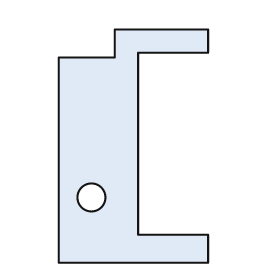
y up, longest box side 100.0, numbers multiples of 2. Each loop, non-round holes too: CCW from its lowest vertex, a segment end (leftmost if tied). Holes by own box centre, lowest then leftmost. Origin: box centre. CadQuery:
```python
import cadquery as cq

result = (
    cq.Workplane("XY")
    .moveTo(-32.0, -50.0)
    .lineTo(32.0, -50.0)
    .lineTo(32.0, -38.0)
    .lineTo(2.0, -38.0)
    .lineTo(2.0, 40.0)
    .lineTo(32.0, 40.0)
    .lineTo(32.0, 50.0)
    .lineTo(-8.0, 50.0)
    .lineTo(-8.0, 38.0)
    .lineTo(-32.0, 38.0)
    .close()
    .moveTo(-18.0, -22.0)
    .circle(6.0)
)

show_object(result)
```